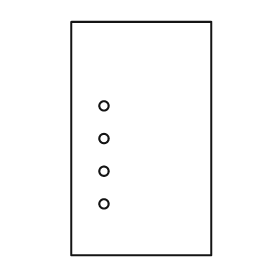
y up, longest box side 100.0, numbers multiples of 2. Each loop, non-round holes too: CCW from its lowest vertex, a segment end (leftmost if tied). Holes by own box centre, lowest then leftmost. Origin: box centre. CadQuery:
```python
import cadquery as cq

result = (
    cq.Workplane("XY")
    .moveTo(-30.0, -50.0)
    .lineTo(30.0, -50.0)
    .lineTo(30.0, 50.0)
    .lineTo(-30.0, 50.0)
    .close()
    .moveTo(-16.0, -28.0)
    .circle(2.0)
    .moveTo(-16.0, -14.0)
    .circle(2.0)
    .moveTo(-16.0, 0.0)
    .circle(2.0)
    .moveTo(-16.0, 14.0)
    .circle(2.0)
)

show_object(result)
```